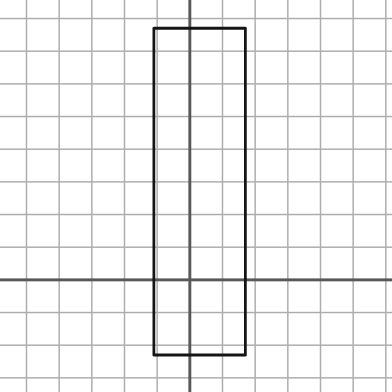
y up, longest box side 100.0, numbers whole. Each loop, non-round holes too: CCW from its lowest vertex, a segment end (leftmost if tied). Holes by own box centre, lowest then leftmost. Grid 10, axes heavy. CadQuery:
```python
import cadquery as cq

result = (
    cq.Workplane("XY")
    .moveTo(-11.0, -23.0)
    .lineTo(17.0, -23.0)
    .lineTo(17.0, 77.0)
    .lineTo(-11.0, 77.0)
    .close()
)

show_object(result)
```